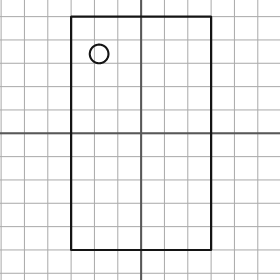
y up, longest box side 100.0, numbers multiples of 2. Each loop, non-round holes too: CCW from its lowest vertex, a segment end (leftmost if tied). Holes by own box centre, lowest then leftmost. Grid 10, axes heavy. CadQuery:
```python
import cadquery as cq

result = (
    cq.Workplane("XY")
    .moveTo(-30.0, -50.0)
    .lineTo(30.0, -50.0)
    .lineTo(30.0, 50.0)
    .lineTo(-30.0, 50.0)
    .close()
    .moveTo(-18.0, 34.0)
    .circle(4.0)
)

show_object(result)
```